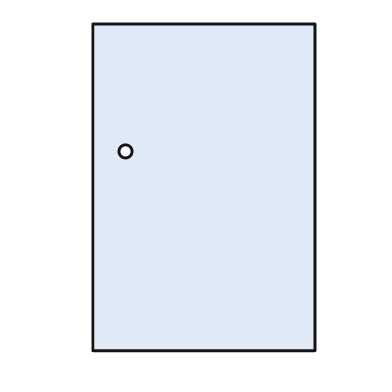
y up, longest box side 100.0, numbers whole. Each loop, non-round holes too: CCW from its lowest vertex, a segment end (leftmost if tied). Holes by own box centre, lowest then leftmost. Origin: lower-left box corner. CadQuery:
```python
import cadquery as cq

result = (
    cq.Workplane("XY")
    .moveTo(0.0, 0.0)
    .lineTo(68.0, 0.0)
    .lineTo(68.0, 100.0)
    .lineTo(0.0, 100.0)
    .close()
    .moveTo(10.0, 61.0)
    .circle(2.0)
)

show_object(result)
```